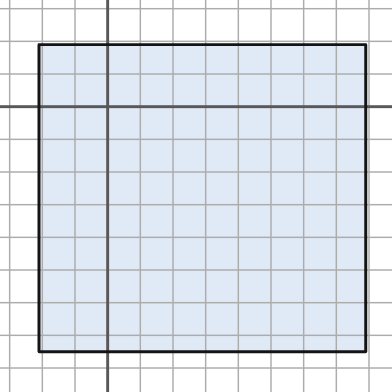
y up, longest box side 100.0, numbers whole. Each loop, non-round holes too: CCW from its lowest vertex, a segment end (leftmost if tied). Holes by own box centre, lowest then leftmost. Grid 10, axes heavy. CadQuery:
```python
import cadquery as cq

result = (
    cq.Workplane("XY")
    .moveTo(-21.0, -75.0)
    .lineTo(79.0, -75.0)
    .lineTo(79.0, 19.0)
    .lineTo(-21.0, 19.0)
    .close()
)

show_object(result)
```